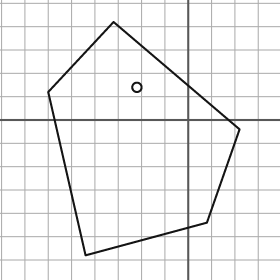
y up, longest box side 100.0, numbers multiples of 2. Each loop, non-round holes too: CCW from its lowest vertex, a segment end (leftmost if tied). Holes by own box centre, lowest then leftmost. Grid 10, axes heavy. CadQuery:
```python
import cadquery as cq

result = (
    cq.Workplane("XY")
    .moveTo(-44.0, -58.0)
    .lineTo(8.0, -44.0)
    .lineTo(22.0, -4.0)
    .lineTo(-32.0, 42.0)
    .lineTo(-60.0, 12.0)
    .close()
    .moveTo(-22.0, 14.0)
    .circle(2.0)
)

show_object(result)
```